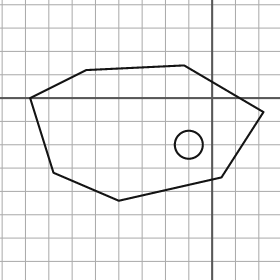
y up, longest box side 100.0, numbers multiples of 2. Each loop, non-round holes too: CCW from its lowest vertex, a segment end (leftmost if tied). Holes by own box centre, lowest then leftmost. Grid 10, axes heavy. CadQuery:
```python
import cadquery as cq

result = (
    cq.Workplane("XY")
    .moveTo(-40.0, -44.0)
    .lineTo(4.0, -34.0)
    .lineTo(22.0, -6.0)
    .lineTo(-12.0, 14.0)
    .lineTo(-54.0, 12.0)
    .lineTo(-78.0, 0.0)
    .lineTo(-68.0, -32.0)
    .close()
    .moveTo(-10.0, -20.0)
    .circle(6.0)
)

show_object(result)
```